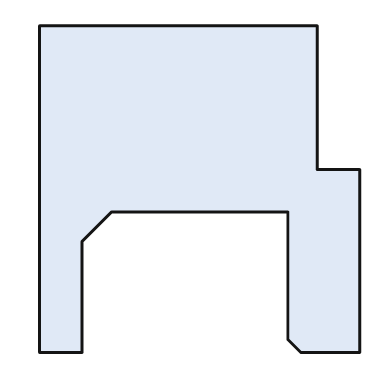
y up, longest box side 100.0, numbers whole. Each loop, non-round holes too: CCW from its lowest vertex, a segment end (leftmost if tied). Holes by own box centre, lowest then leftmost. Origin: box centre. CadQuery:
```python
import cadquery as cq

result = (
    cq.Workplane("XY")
    .moveTo(-49.0, -50.0)
    .lineTo(-36.0, -50.0)
    .lineTo(-36.0, -16.0)
    .lineTo(-27.0, -7.0)
    .lineTo(27.0, -7.0)
    .lineTo(27.0, -46.0)
    .lineTo(31.0, -50.0)
    .lineTo(49.0, -50.0)
    .lineTo(49.0, 6.0)
    .lineTo(36.0, 6.0)
    .lineTo(36.0, 50.0)
    .lineTo(-49.0, 50.0)
    .close()
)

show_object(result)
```